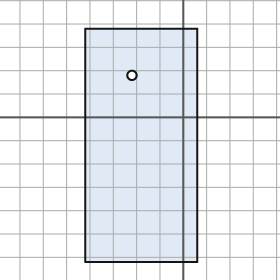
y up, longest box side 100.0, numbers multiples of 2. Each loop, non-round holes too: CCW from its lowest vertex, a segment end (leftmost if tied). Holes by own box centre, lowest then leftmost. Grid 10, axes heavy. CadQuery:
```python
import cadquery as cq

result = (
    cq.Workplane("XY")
    .moveTo(-42.0, -62.0)
    .lineTo(6.0, -62.0)
    .lineTo(6.0, 38.0)
    .lineTo(-42.0, 38.0)
    .close()
    .moveTo(-22.0, 18.0)
    .circle(2.0)
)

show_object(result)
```